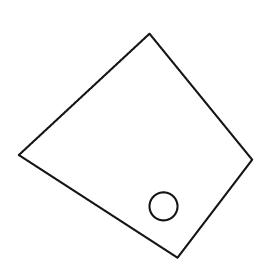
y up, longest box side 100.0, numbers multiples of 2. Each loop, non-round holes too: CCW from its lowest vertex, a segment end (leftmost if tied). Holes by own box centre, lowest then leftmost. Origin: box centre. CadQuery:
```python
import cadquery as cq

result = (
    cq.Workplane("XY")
    .moveTo(18.0, -48.0)
    .lineTo(50.0, -6.0)
    .lineTo(6.0, 48.0)
    .lineTo(-50.0, -4.0)
    .close()
    .moveTo(12.0, -26.0)
    .circle(6.0)
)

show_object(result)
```